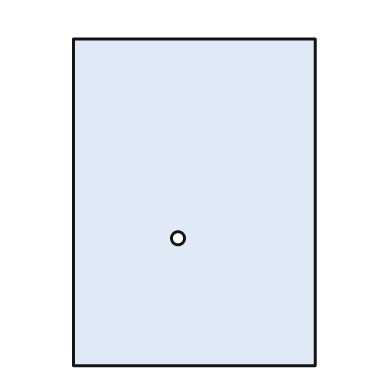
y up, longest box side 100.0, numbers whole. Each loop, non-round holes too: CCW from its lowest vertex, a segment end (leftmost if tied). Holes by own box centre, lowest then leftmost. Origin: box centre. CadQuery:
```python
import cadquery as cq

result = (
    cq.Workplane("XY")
    .moveTo(-37.0, -50.0)
    .lineTo(37.0, -50.0)
    .lineTo(37.0, 50.0)
    .lineTo(-37.0, 50.0)
    .close()
    .moveTo(-5.0, -11.0)
    .circle(2.0)
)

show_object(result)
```